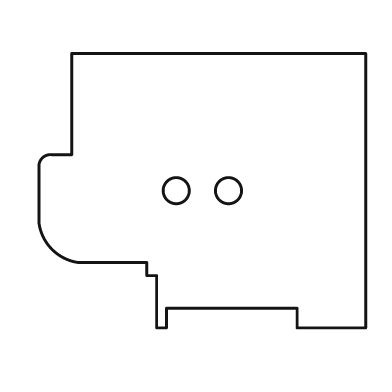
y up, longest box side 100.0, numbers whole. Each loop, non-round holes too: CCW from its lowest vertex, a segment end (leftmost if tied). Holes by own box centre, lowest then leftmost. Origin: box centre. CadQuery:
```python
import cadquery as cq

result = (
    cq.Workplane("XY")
    .moveTo(-14.0, -42.0)
    .lineTo(-11.0, -42.0)
    .lineTo(-11.0, -36.0)
    .lineTo(29.0, -36.0)
    .lineTo(29.0, -42.0)
    .lineTo(50.0, -42.0)
    .lineTo(50.0, 42.0)
    .lineTo(-40.0, 42.0)
    .lineTo(-40.0, 11.0)
    .lineTo(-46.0, 11.0)
    .threePointArc((-49.0, 10.0), (-50.0, 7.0))
    .lineTo(-50.0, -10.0)
    .threePointArc((-46.0, -18.0), (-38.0, -22.0))
    .lineTo(-17.0, -22.0)
    .lineTo(-17.0, -26.0)
    .lineTo(-14.0, -26.0)
    .close()
    .moveTo(-8.0, 0.0)
    .circle(4.0)
    .moveTo(8.0, 0.0)
    .circle(4.0)
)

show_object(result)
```